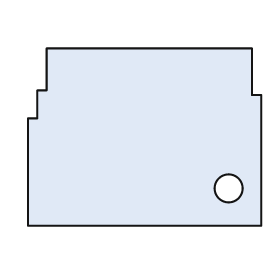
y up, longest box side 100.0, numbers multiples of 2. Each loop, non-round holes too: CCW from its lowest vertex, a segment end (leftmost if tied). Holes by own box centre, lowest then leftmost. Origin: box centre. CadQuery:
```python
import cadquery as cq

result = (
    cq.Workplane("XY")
    .moveTo(-50.0, -38.0)
    .lineTo(50.0, -38.0)
    .lineTo(50.0, 18.0)
    .lineTo(46.0, 18.0)
    .lineTo(46.0, 38.0)
    .lineTo(-42.0, 38.0)
    .lineTo(-42.0, 20.0)
    .lineTo(-46.0, 20.0)
    .lineTo(-46.0, 8.0)
    .lineTo(-50.0, 8.0)
    .close()
    .moveTo(36.0, -22.0)
    .circle(6.0)
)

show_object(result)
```